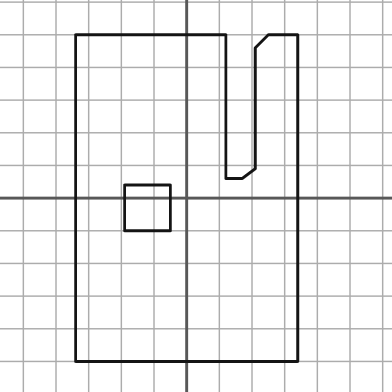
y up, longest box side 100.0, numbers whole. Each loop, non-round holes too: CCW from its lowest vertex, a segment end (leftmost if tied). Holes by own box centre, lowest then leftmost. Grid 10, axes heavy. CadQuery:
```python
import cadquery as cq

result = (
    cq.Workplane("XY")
    .moveTo(-34.0, -50.0)
    .lineTo(34.0, -50.0)
    .lineTo(34.0, 50.0)
    .lineTo(25.0, 50.0)
    .lineTo(21.0, 46.0)
    .lineTo(21.0, 9.0)
    .lineTo(17.0, 6.0)
    .lineTo(12.0, 6.0)
    .lineTo(12.0, 50.0)
    .lineTo(-34.0, 50.0)
    .close()
    .moveTo(-19.0, -10.0)
    .lineTo(-5.0, -10.0)
    .lineTo(-5.0, 4.0)
    .lineTo(-19.0, 4.0)
    .close()
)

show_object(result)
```